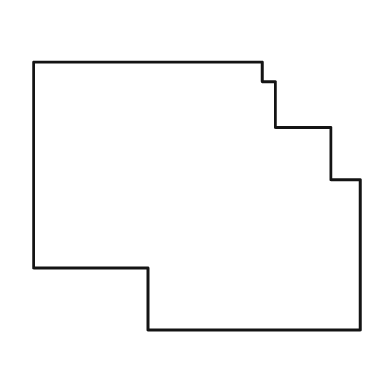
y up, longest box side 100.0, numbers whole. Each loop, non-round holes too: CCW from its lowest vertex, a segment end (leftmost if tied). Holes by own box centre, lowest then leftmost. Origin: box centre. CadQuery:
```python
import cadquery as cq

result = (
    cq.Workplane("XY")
    .moveTo(-15.0, -41.0)
    .lineTo(50.0, -41.0)
    .lineTo(50.0, 5.0)
    .lineTo(41.0, 5.0)
    .lineTo(41.0, 21.0)
    .lineTo(24.0, 21.0)
    .lineTo(24.0, 35.0)
    .lineTo(20.0, 35.0)
    .lineTo(20.0, 41.0)
    .lineTo(-50.0, 41.0)
    .lineTo(-50.0, -22.0)
    .lineTo(-15.0, -22.0)
    .close()
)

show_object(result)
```